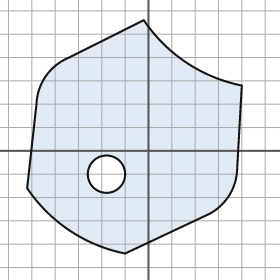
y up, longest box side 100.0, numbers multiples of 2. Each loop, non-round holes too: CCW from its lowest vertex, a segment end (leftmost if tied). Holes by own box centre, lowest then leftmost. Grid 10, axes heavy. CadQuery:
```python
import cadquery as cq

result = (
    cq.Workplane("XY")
    .moveTo(-10.0, -44.0)
    .lineTo(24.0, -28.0)
    .threePointArc((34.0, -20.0), (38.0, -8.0))
    .lineTo(40.0, 28.0)
    .threePointArc((16.0, 38.0), (-2.0, 56.0))
    .lineTo(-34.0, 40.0)
    .threePointArc((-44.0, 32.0), (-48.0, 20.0))
    .lineTo(-52.0, -16.0)
    .threePointArc((-34.0, -34.0), (-10.0, -44.0))
    .close()
    .moveTo(-18.0, -10.0)
    .circle(8.0)
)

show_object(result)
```